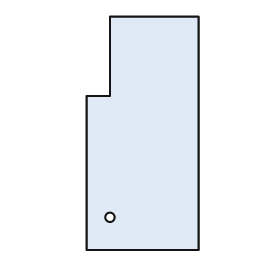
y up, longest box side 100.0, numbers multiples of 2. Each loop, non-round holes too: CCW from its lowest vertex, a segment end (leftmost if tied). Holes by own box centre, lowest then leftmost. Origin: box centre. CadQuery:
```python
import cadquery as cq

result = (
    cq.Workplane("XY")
    .moveTo(-24.0, -50.0)
    .lineTo(24.0, -50.0)
    .lineTo(24.0, 50.0)
    .lineTo(-14.0, 50.0)
    .lineTo(-14.0, 16.0)
    .lineTo(-24.0, 16.0)
    .close()
    .moveTo(-14.0, -36.0)
    .circle(2.0)
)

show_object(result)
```